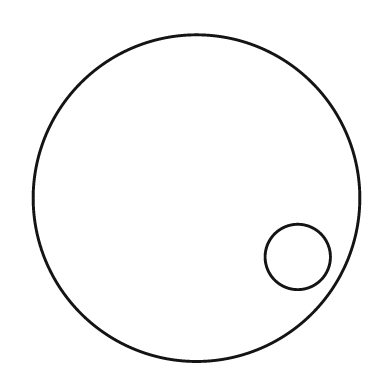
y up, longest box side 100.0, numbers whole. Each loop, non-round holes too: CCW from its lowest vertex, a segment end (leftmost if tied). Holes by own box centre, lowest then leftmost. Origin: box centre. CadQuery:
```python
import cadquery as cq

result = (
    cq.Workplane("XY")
    .moveTo(0.0, 0.0)
    .circle(50.0)
    .moveTo(31.0, -18.0)
    .circle(10.0)
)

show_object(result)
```